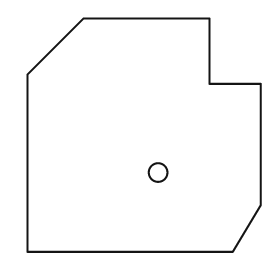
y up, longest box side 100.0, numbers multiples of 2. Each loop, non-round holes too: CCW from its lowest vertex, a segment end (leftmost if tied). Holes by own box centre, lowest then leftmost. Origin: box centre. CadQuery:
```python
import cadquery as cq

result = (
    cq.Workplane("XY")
    .moveTo(-50.0, -50.0)
    .lineTo(38.0, -50.0)
    .lineTo(50.0, -30.0)
    .lineTo(50.0, 22.0)
    .lineTo(28.0, 22.0)
    .lineTo(28.0, 50.0)
    .lineTo(-26.0, 50.0)
    .lineTo(-50.0, 26.0)
    .close()
    .moveTo(6.0, -16.0)
    .circle(4.0)
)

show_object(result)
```